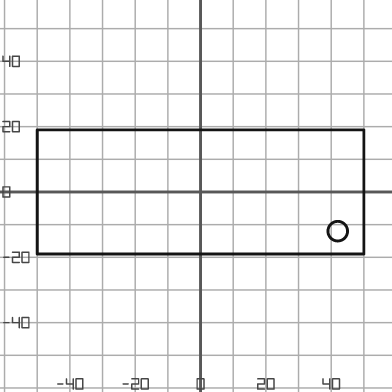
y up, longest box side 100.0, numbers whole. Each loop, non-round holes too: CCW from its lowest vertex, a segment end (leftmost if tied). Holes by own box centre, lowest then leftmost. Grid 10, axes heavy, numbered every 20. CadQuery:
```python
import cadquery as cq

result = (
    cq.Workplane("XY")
    .moveTo(-50.0, -19.0)
    .lineTo(50.0, -19.0)
    .lineTo(50.0, 19.0)
    .lineTo(-50.0, 19.0)
    .close()
    .moveTo(42.0, -12.0)
    .circle(3.0)
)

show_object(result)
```